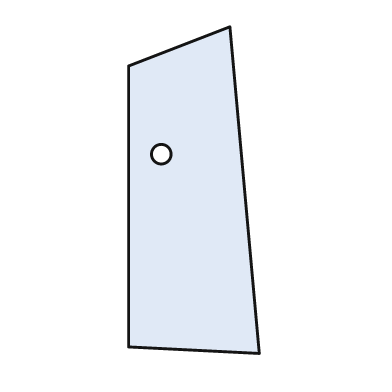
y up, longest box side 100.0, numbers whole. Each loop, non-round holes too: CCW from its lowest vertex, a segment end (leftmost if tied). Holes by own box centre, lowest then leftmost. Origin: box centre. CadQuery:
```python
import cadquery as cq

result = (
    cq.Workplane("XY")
    .moveTo(20.0, -50.0)
    .lineTo(11.0, 50.0)
    .lineTo(-20.0, 38.0)
    .lineTo(-20.0, -48.0)
    .close()
    .moveTo(-10.0, 11.0)
    .circle(3.0)
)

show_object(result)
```